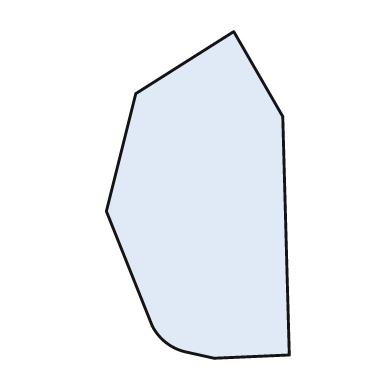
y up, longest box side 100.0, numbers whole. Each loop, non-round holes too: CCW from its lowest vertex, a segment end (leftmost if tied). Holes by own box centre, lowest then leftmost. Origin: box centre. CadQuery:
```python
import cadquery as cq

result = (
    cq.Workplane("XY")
    .moveTo(5.0, -50.0)
    .lineTo(28.0, -49.0)
    .lineTo(26.0, 24.0)
    .lineTo(11.0, 50.0)
    .lineTo(-19.0, 31.0)
    .lineTo(-28.0, -5.0)
    .lineTo(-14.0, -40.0)
    .threePointArc((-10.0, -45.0), (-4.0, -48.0))
    .close()
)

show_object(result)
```